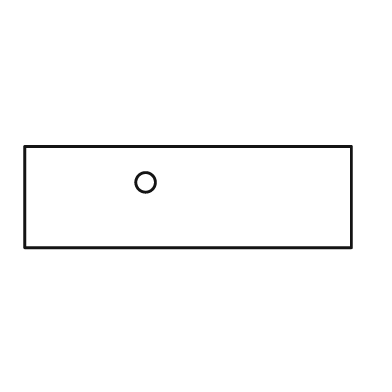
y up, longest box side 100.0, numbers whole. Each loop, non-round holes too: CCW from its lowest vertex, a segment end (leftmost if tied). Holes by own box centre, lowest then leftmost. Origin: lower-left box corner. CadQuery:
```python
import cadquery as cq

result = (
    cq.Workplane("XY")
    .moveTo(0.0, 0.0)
    .lineTo(100.0, 0.0)
    .lineTo(100.0, 31.0)
    .lineTo(0.0, 31.0)
    .close()
    .moveTo(37.0, 20.0)
    .circle(3.0)
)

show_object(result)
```